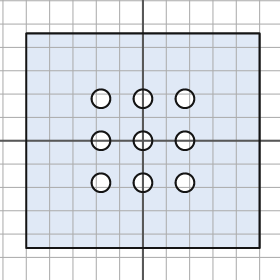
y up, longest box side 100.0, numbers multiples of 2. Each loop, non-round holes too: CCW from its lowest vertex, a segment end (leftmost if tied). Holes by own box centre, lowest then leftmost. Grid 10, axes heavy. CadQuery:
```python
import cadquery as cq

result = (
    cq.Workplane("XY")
    .moveTo(-50.0, -46.0)
    .lineTo(50.0, -46.0)
    .lineTo(50.0, 46.0)
    .lineTo(-50.0, 46.0)
    .close()
    .moveTo(-18.0, -18.0)
    .circle(4.0)
    .moveTo(0.0, -18.0)
    .circle(4.0)
    .moveTo(18.0, -18.0)
    .circle(4.0)
    .moveTo(-18.0, 0.0)
    .circle(4.0)
    .moveTo(0.0, 0.0)
    .circle(4.0)
    .moveTo(18.0, 0.0)
    .circle(4.0)
    .moveTo(-18.0, 18.0)
    .circle(4.0)
    .moveTo(0.0, 18.0)
    .circle(4.0)
    .moveTo(18.0, 18.0)
    .circle(4.0)
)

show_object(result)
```